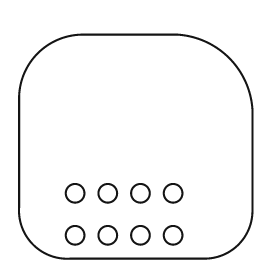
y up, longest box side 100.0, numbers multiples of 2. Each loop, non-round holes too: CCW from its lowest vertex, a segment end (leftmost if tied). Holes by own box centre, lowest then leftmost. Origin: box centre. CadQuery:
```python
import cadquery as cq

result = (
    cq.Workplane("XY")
    .moveTo(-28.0, -48.0)
    .lineTo(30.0, -48.0)
    .threePointArc((44.0, -42.0), (50.0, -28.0))
    .lineTo(50.0, 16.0)
    .threePointArc((40.0, 38.0), (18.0, 48.0))
    .lineTo(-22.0, 48.0)
    .threePointArc((-42.0, 40.0), (-50.0, 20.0))
    .lineTo(-50.0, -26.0)
    .threePointArc((-44.0, -42.0), (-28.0, -48.0))
    .close()
    .moveTo(-26.0, -38.0)
    .circle(4.0)
    .moveTo(-12.0, -38.0)
    .circle(4.0)
    .moveTo(2.0, -38.0)
    .circle(4.0)
    .moveTo(16.0, -38.0)
    .circle(4.0)
    .moveTo(-26.0, -20.0)
    .circle(4.0)
    .moveTo(-12.0, -20.0)
    .circle(4.0)
    .moveTo(2.0, -20.0)
    .circle(4.0)
    .moveTo(16.0, -20.0)
    .circle(4.0)
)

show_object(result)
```